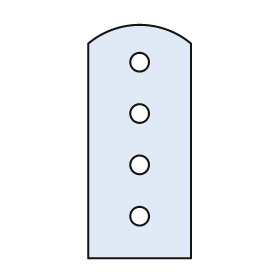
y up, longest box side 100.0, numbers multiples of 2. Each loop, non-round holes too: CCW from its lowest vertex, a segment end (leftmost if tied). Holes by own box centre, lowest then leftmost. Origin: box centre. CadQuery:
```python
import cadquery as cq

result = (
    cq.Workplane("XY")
    .moveTo(-22.0, -50.0)
    .lineTo(22.0, -50.0)
    .lineTo(22.0, 42.0)
    .threePointArc((0.0, 50.0), (-22.0, 42.0))
    .close()
    .moveTo(0.0, -32.0)
    .circle(4.0)
    .moveTo(0.0, -10.0)
    .circle(4.0)
    .moveTo(0.0, 12.0)
    .circle(4.0)
    .moveTo(0.0, 34.0)
    .circle(4.0)
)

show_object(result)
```